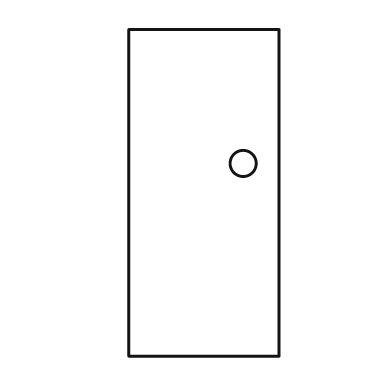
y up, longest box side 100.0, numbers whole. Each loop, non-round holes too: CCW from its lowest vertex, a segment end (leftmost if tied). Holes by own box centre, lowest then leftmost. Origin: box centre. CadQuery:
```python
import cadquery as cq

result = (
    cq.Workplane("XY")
    .moveTo(-23.0, -50.0)
    .lineTo(23.0, -50.0)
    .lineTo(23.0, 50.0)
    .lineTo(-23.0, 50.0)
    .close()
    .moveTo(12.0, 9.0)
    .circle(4.0)
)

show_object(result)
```